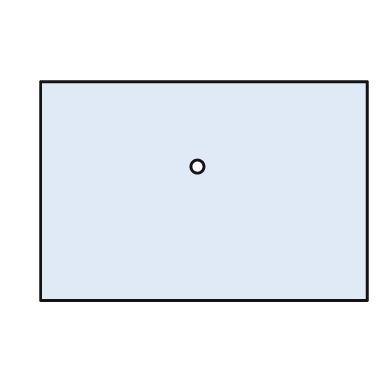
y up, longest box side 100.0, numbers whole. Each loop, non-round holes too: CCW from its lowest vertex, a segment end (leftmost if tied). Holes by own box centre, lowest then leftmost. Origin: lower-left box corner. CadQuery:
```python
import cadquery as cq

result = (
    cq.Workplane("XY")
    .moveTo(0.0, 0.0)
    .lineTo(100.0, 0.0)
    .lineTo(100.0, 67.0)
    .lineTo(0.0, 67.0)
    .close()
    .moveTo(48.0, 41.0)
    .circle(2.0)
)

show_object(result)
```